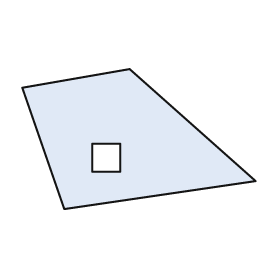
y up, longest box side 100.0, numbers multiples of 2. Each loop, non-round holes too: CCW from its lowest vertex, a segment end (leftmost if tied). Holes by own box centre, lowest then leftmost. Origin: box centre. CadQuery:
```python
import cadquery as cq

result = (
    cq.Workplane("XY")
    .moveTo(-32.0, -30.0)
    .lineTo(50.0, -18.0)
    .lineTo(-4.0, 30.0)
    .lineTo(-50.0, 22.0)
    .close()
    .moveTo(-20.0, -14.0)
    .lineTo(-8.0, -14.0)
    .lineTo(-8.0, -2.0)
    .lineTo(-20.0, -2.0)
    .close()
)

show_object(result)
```